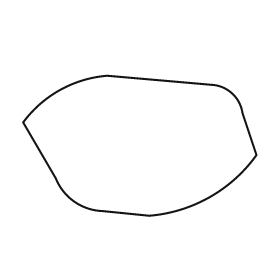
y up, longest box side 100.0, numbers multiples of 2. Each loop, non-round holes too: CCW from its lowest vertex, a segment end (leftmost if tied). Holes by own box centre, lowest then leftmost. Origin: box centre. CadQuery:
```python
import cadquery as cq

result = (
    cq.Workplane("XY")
    .moveTo(4.0, -30.0)
    .threePointArc((30.0, -22.0), (50.0, -4.0))
    .lineTo(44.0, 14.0)
    .threePointArc((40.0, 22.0), (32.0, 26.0))
    .lineTo(-14.0, 30.0)
    .threePointArc((-34.0, 24.0), (-50.0, 10.0))
    .lineTo(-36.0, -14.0)
    .threePointArc((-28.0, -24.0), (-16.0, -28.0))
    .close()
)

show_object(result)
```